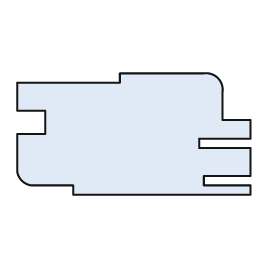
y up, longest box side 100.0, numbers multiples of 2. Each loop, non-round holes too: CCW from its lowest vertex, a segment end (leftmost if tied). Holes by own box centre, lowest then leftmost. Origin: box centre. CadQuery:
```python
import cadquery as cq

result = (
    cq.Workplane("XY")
    .moveTo(-26.0, -26.0)
    .lineTo(50.0, -26.0)
    .lineTo(50.0, -22.0)
    .lineTo(30.0, -22.0)
    .lineTo(30.0, -18.0)
    .lineTo(50.0, -18.0)
    .lineTo(50.0, -6.0)
    .lineTo(28.0, -6.0)
    .lineTo(28.0, -2.0)
    .lineTo(50.0, -2.0)
    .lineTo(50.0, 6.0)
    .lineTo(38.0, 6.0)
    .lineTo(38.0, 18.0)
    .threePointArc((36.0, 24.0), (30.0, 26.0))
    .lineTo(-6.0, 26.0)
    .lineTo(-6.0, 22.0)
    .lineTo(-50.0, 22.0)
    .lineTo(-50.0, 10.0)
    .lineTo(-38.0, 10.0)
    .lineTo(-38.0, 0.0)
    .lineTo(-50.0, 0.0)
    .lineTo(-50.0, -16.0)
    .threePointArc((-48.0, -20.0), (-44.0, -22.0))
    .lineTo(-26.0, -22.0)
    .close()
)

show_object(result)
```